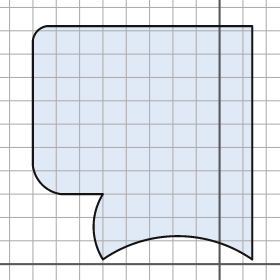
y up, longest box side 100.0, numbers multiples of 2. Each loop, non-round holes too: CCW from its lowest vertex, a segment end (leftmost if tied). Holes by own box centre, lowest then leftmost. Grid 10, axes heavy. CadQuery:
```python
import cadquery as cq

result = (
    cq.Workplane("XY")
    .moveTo(-50.0, 2.0)
    .threePointArc((-18.0, 12.0), (14.0, 2.0))
    .lineTo(14.0, 102.0)
    .lineTo(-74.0, 102.0)
    .threePointArc((-78.0, 100.0), (-80.0, 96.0))
    .lineTo(-80.0, 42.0)
    .threePointArc((-76.0, 34.0), (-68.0, 30.0))
    .lineTo(-50.0, 30.0)
    .threePointArc((-54.0, 16.0), (-50.0, 2.0))
    .close()
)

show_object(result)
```